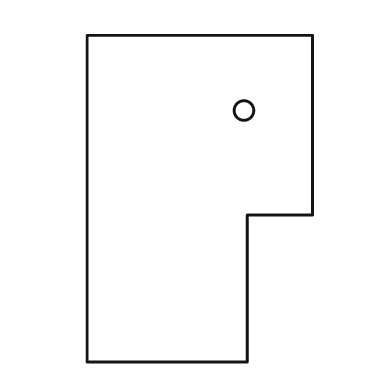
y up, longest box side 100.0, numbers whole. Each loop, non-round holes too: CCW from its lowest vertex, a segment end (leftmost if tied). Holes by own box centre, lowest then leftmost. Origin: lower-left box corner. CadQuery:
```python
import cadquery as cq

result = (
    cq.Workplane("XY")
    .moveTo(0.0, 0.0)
    .lineTo(49.0, 0.0)
    .lineTo(49.0, 45.0)
    .lineTo(69.0, 45.0)
    .lineTo(69.0, 100.0)
    .lineTo(0.0, 100.0)
    .close()
    .moveTo(48.0, 77.0)
    .circle(3.0)
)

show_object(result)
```